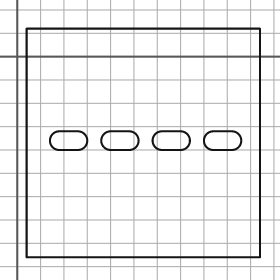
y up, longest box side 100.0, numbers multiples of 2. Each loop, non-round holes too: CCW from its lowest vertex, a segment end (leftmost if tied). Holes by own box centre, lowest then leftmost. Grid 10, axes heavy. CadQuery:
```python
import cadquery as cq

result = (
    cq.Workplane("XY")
    .moveTo(4.0, -86.0)
    .lineTo(104.0, -86.0)
    .lineTo(104.0, 12.0)
    .lineTo(4.0, 12.0)
    .close()
    .moveTo(18.0, -40.0)
    .lineTo(26.0, -40.0)
    .threePointArc((30.0, -36.0), (26.0, -32.0))
    .lineTo(18.0, -32.0)
    .threePointArc((14.0, -36.0), (18.0, -40.0))
    .close()
    .moveTo(40.0, -40.0)
    .lineTo(48.0, -40.0)
    .threePointArc((52.0, -36.0), (48.0, -32.0))
    .lineTo(40.0, -32.0)
    .threePointArc((36.0, -36.0), (40.0, -40.0))
    .close()
    .moveTo(62.0, -40.0)
    .lineTo(70.0, -40.0)
    .threePointArc((74.0, -36.0), (70.0, -32.0))
    .lineTo(62.0, -32.0)
    .threePointArc((58.0, -36.0), (62.0, -40.0))
    .close()
    .moveTo(84.0, -40.0)
    .lineTo(92.0, -40.0)
    .threePointArc((96.0, -36.0), (92.0, -32.0))
    .lineTo(84.0, -32.0)
    .threePointArc((80.0, -36.0), (84.0, -40.0))
    .close()
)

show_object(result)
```